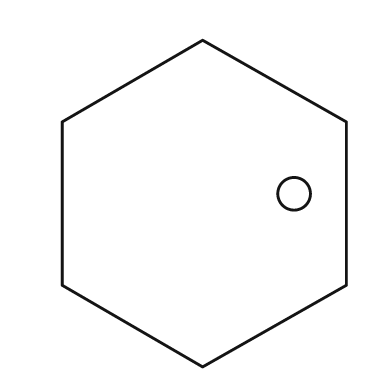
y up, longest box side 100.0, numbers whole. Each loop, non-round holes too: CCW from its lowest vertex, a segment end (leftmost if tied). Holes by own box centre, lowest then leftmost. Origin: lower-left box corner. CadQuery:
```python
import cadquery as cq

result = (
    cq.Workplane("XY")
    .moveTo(43.0, 0.0)
    .lineTo(87.0, 25.0)
    .lineTo(87.0, 75.0)
    .lineTo(43.0, 100.0)
    .lineTo(0.0, 75.0)
    .lineTo(0.0, 25.0)
    .close()
    .moveTo(71.0, 53.0)
    .circle(5.0)
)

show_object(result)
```